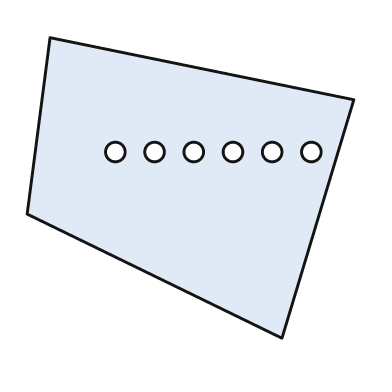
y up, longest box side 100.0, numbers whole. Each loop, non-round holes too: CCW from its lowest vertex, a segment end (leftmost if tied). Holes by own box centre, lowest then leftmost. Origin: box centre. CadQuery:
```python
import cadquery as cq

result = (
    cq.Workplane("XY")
    .moveTo(28.0, -46.0)
    .lineTo(50.0, 27.0)
    .lineTo(-43.0, 46.0)
    .lineTo(-50.0, -8.0)
    .close()
    .moveTo(-23.0, 11.0)
    .circle(3.0)
    .moveTo(-11.0, 11.0)
    .circle(3.0)
    .moveTo(1.0, 11.0)
    .circle(3.0)
    .moveTo(13.0, 11.0)
    .circle(3.0)
    .moveTo(25.0, 11.0)
    .circle(3.0)
    .moveTo(37.0, 11.0)
    .circle(3.0)
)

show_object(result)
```